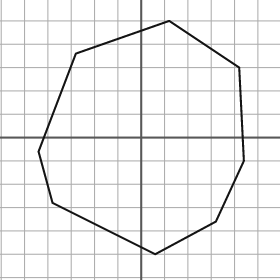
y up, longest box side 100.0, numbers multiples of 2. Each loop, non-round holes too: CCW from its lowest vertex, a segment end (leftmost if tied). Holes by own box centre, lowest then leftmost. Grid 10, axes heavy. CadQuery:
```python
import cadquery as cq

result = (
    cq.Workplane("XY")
    .moveTo(6.0, -50.0)
    .lineTo(32.0, -36.0)
    .lineTo(44.0, -10.0)
    .lineTo(42.0, 30.0)
    .lineTo(12.0, 50.0)
    .lineTo(-28.0, 36.0)
    .lineTo(-44.0, -6.0)
    .lineTo(-38.0, -28.0)
    .close()
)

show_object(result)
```